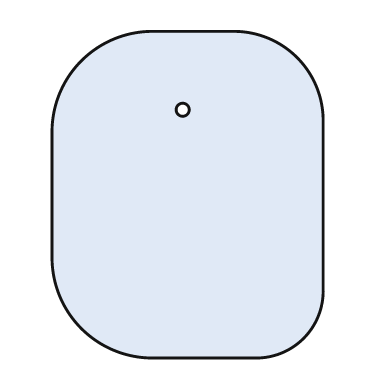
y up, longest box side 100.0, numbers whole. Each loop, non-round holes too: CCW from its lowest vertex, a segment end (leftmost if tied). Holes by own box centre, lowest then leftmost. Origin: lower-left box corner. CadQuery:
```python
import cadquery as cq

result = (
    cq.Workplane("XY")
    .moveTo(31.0, 0.0)
    .lineTo(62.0, 0.0)
    .threePointArc((77.0, 6.0), (83.0, 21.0))
    .lineTo(83.0, 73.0)
    .threePointArc((75.0, 92.0), (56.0, 100.0))
    .lineTo(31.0, 100.0)
    .threePointArc((9.0, 91.0), (0.0, 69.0))
    .lineTo(0.0, 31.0)
    .threePointArc((9.0, 9.0), (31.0, 0.0))
    .close()
    .moveTo(40.0, 76.0)
    .circle(2.0)
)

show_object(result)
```